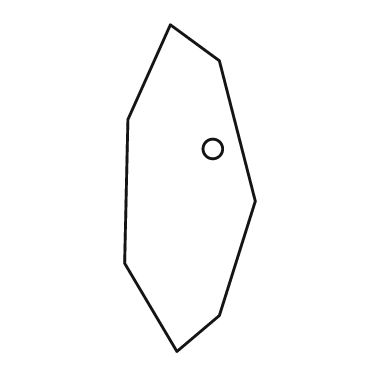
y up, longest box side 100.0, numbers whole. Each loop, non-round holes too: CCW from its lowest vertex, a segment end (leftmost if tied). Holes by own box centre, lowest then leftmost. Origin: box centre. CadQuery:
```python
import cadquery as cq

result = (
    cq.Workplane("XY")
    .moveTo(-4.0, -50.0)
    .lineTo(9.0, -39.0)
    .lineTo(20.0, -4.0)
    .lineTo(9.0, 39.0)
    .lineTo(-6.0, 50.0)
    .lineTo(-19.0, 21.0)
    .lineTo(-20.0, -23.0)
    .close()
    .moveTo(7.0, 12.0)
    .circle(3.0)
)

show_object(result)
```